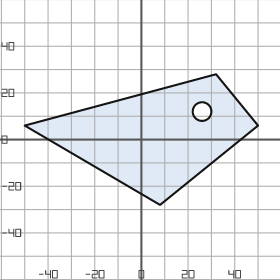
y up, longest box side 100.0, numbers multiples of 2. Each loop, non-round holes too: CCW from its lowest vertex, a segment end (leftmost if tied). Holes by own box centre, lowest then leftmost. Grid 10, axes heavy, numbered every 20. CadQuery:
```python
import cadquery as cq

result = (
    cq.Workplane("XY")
    .moveTo(8.0, -28.0)
    .lineTo(50.0, 6.0)
    .lineTo(32.0, 28.0)
    .lineTo(-50.0, 6.0)
    .close()
    .moveTo(26.0, 12.0)
    .circle(4.0)
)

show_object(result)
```